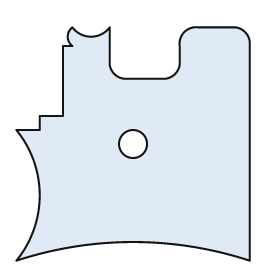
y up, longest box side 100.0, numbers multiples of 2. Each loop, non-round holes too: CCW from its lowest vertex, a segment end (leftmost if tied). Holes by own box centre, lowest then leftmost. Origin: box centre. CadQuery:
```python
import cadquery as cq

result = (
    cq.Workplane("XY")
    .moveTo(-50.0, -50.0)
    .threePointArc((0.0, -42.0), (50.0, -50.0))
    .lineTo(50.0, 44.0)
    .threePointArc((48.0, 48.0), (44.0, 50.0))
    .lineTo(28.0, 50.0)
    .threePointArc((22.0, 48.0), (20.0, 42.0))
    .lineTo(20.0, 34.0)
    .threePointArc((18.0, 30.0), (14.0, 28.0))
    .lineTo(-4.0, 28.0)
    .threePointArc((-8.0, 30.0), (-10.0, 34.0))
    .lineTo(-10.0, 50.0)
    .threePointArc((-18.0, 46.0), (-26.0, 50.0))
    .threePointArc((-28.0, 46.0), (-26.0, 42.0))
    .lineTo(-30.0, 42.0)
    .lineTo(-30.0, 12.0)
    .lineTo(-40.0, 12.0)
    .lineTo(-40.0, 6.0)
    .lineTo(-50.0, 6.0)
    .threePointArc((-40.0, -22.0), (-50.0, -50.0))
    .close()
    .moveTo(0.0, 0.0)
    .circle(6.0)
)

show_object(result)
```